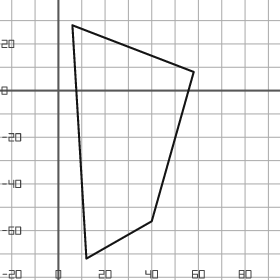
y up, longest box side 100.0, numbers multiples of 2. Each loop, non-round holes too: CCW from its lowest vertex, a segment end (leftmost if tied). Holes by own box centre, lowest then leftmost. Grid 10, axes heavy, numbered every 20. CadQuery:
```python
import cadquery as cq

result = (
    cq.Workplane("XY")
    .moveTo(12.0, -72.0)
    .lineTo(40.0, -56.0)
    .lineTo(58.0, 8.0)
    .lineTo(6.0, 28.0)
    .close()
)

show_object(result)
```